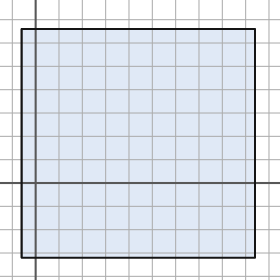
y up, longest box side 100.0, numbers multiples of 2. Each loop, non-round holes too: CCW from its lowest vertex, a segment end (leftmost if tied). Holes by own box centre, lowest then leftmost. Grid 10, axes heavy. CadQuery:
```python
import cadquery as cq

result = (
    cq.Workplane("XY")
    .moveTo(-6.0, -32.0)
    .lineTo(94.0, -32.0)
    .lineTo(94.0, 66.0)
    .lineTo(-6.0, 66.0)
    .close()
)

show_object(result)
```